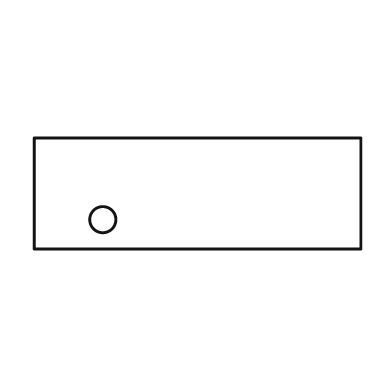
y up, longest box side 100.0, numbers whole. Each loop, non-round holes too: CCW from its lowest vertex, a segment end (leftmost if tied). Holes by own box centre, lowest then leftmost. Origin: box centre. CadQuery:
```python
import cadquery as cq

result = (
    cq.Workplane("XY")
    .moveTo(-50.0, -17.0)
    .lineTo(50.0, -17.0)
    .lineTo(50.0, 17.0)
    .lineTo(-50.0, 17.0)
    .close()
    .moveTo(-29.0, -8.0)
    .circle(4.0)
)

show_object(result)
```